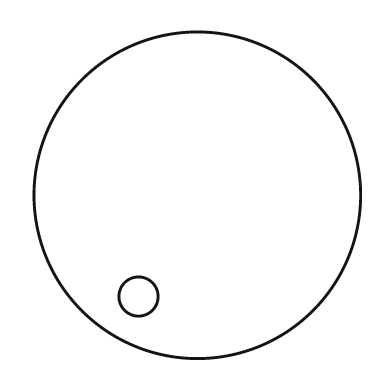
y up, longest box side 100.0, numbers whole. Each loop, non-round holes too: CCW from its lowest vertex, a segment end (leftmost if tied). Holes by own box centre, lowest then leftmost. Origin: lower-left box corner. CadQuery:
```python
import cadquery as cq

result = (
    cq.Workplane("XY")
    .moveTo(50.0, 50.0)
    .circle(50.0)
    .moveTo(32.0, 19.0)
    .circle(6.0)
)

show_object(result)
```